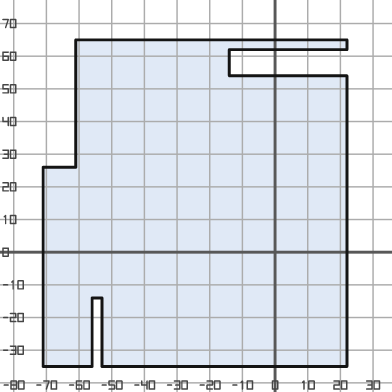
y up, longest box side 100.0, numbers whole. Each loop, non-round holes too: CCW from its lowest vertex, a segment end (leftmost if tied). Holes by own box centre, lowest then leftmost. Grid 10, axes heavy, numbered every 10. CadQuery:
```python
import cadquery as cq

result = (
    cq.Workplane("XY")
    .moveTo(-71.0, -35.0)
    .lineTo(-56.0, -35.0)
    .lineTo(-56.0, -14.0)
    .lineTo(-53.0, -14.0)
    .lineTo(-53.0, -35.0)
    .lineTo(22.0, -35.0)
    .lineTo(22.0, 54.0)
    .lineTo(-14.0, 54.0)
    .lineTo(-14.0, 62.0)
    .lineTo(22.0, 62.0)
    .lineTo(22.0, 65.0)
    .lineTo(-61.0, 65.0)
    .lineTo(-61.0, 26.0)
    .lineTo(-71.0, 26.0)
    .close()
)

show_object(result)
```